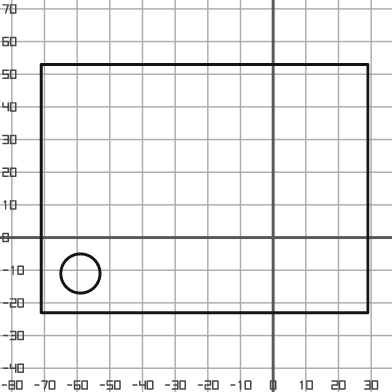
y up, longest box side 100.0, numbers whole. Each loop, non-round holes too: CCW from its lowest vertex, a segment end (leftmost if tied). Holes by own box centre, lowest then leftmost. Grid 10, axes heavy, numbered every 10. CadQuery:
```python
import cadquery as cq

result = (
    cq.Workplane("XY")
    .moveTo(-71.0, -23.0)
    .lineTo(29.0, -23.0)
    .lineTo(29.0, 53.0)
    .lineTo(-71.0, 53.0)
    .close()
    .moveTo(-59.0, -11.0)
    .circle(6.0)
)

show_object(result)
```